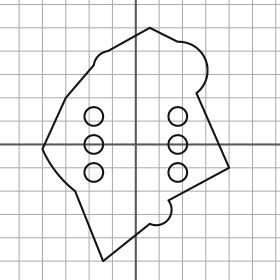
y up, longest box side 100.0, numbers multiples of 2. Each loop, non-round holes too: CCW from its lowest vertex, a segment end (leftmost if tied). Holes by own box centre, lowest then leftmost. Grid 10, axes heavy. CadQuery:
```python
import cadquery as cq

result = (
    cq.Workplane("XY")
    .moveTo(-14.0, -50.0)
    .lineTo(6.0, -34.0)
    .threePointArc((14.0, -32.0), (14.0, -24.0))
    .lineTo(40.0, -10.0)
    .lineTo(26.0, 22.0)
    .threePointArc((30.0, 36.0), (18.0, 44.0))
    .lineTo(6.0, 50.0)
    .lineTo(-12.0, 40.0)
    .threePointArc((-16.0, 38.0), (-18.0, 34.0))
    .lineTo(-30.0, 20.0)
    .lineTo(-40.0, -2.0)
    .threePointArc((-34.0, -12.0), (-26.0, -20.0))
    .close()
    .moveTo(-18.0, -12.0)
    .circle(4.0)
    .moveTo(18.0, -12.0)
    .circle(4.0)
    .moveTo(-18.0, 0.0)
    .circle(4.0)
    .moveTo(18.0, 0.0)
    .circle(4.0)
    .moveTo(-18.0, 12.0)
    .circle(4.0)
    .moveTo(18.0, 12.0)
    .circle(4.0)
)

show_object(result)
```